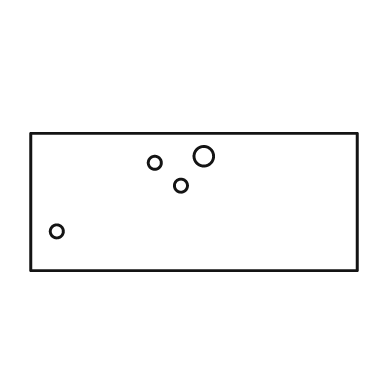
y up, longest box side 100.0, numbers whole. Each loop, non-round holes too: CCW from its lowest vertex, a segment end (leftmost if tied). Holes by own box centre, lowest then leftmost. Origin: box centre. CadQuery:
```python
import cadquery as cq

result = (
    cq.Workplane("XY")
    .moveTo(-50.0, -21.0)
    .lineTo(50.0, -21.0)
    .lineTo(50.0, 21.0)
    .lineTo(-50.0, 21.0)
    .close()
    .moveTo(-42.0, -9.0)
    .circle(2.0)
    .moveTo(-4.0, 5.0)
    .circle(2.0)
    .moveTo(-12.0, 12.0)
    .circle(2.0)
    .moveTo(3.0, 14.0)
    .circle(3.0)
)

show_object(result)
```